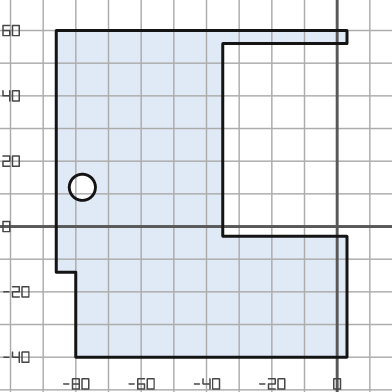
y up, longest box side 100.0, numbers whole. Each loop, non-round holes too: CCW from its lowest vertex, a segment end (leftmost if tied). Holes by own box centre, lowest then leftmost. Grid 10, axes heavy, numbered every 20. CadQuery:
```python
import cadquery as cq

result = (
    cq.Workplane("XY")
    .moveTo(-80.0, -40.0)
    .lineTo(3.0, -40.0)
    .lineTo(3.0, -3.0)
    .lineTo(-35.0, -3.0)
    .lineTo(-35.0, 56.0)
    .lineTo(3.0, 56.0)
    .lineTo(3.0, 60.0)
    .lineTo(-86.0, 60.0)
    .lineTo(-86.0, -14.0)
    .lineTo(-80.0, -14.0)
    .close()
    .moveTo(-78.0, 12.0)
    .circle(4.0)
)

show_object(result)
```